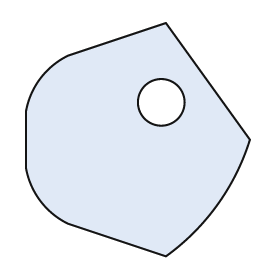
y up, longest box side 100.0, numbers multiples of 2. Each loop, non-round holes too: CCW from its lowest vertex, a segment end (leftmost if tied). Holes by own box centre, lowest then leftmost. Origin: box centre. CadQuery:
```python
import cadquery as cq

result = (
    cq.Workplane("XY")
    .moveTo(12.0, -50.0)
    .threePointArc((34.0, -28.0), (48.0, 0.0))
    .lineTo(12.0, 50.0)
    .lineTo(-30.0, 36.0)
    .threePointArc((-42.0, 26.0), (-48.0, 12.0))
    .lineTo(-48.0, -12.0)
    .threePointArc((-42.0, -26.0), (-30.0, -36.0))
    .close()
    .moveTo(10.0, 16.0)
    .circle(10.0)
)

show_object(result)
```